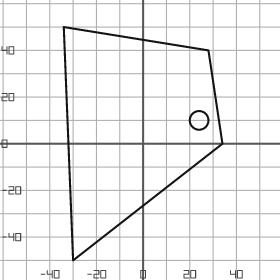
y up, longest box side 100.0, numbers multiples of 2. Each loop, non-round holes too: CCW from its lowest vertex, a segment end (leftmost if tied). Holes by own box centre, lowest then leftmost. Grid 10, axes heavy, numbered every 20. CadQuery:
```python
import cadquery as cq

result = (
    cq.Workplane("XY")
    .moveTo(-30.0, -50.0)
    .lineTo(34.0, 0.0)
    .lineTo(28.0, 40.0)
    .lineTo(-34.0, 50.0)
    .close()
    .moveTo(24.0, 10.0)
    .circle(4.0)
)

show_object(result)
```